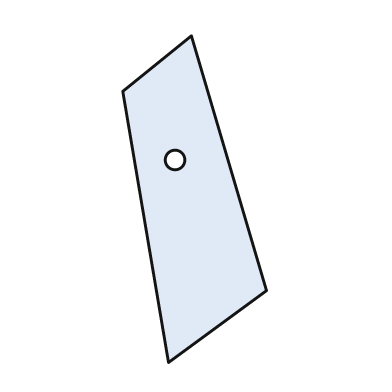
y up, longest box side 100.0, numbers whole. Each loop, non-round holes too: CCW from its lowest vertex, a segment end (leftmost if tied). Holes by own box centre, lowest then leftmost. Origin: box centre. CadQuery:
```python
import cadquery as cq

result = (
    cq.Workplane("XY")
    .moveTo(-8.0, -50.0)
    .lineTo(22.0, -28.0)
    .lineTo(-1.0, 50.0)
    .lineTo(-22.0, 33.0)
    .close()
    .moveTo(-6.0, 12.0)
    .circle(3.0)
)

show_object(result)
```